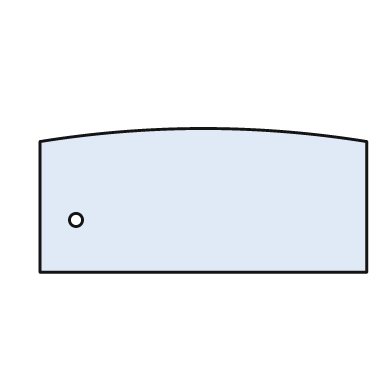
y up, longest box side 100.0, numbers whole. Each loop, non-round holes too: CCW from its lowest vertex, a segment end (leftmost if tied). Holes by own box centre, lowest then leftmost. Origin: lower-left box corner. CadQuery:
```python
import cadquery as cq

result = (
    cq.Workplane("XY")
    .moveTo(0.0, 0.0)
    .lineTo(100.0, 0.0)
    .lineTo(100.0, 40.0)
    .threePointArc((50.0, 44.0), (0.0, 40.0))
    .close()
    .moveTo(11.0, 16.0)
    .circle(2.0)
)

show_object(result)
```